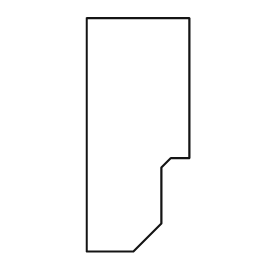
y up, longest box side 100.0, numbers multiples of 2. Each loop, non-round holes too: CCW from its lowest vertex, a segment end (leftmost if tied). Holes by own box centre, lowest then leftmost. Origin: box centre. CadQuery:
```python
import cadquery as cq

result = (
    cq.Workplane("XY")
    .moveTo(-22.0, -50.0)
    .lineTo(-2.0, -50.0)
    .lineTo(10.0, -38.0)
    .lineTo(10.0, -14.0)
    .lineTo(14.0, -10.0)
    .lineTo(22.0, -10.0)
    .lineTo(22.0, 50.0)
    .lineTo(-22.0, 50.0)
    .close()
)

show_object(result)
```